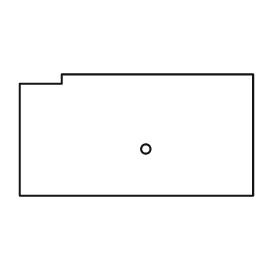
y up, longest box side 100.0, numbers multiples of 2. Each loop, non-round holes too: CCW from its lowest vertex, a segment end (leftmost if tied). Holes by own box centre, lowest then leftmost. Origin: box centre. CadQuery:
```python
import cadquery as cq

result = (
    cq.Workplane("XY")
    .moveTo(-50.0, -26.0)
    .lineTo(50.0, -26.0)
    .lineTo(50.0, 26.0)
    .lineTo(-32.0, 26.0)
    .lineTo(-32.0, 22.0)
    .lineTo(-50.0, 22.0)
    .close()
    .moveTo(4.0, -6.0)
    .circle(2.0)
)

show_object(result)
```